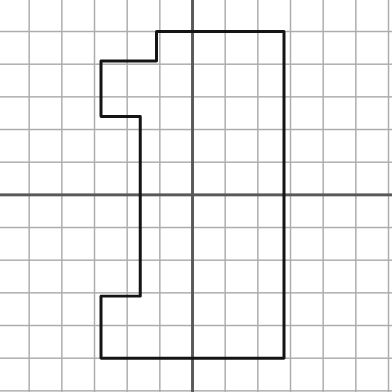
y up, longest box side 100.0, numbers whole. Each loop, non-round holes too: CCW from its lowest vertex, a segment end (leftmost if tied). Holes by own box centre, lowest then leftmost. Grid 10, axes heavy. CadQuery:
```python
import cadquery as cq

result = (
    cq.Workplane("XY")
    .moveTo(-28.0, -50.0)
    .lineTo(28.0, -50.0)
    .lineTo(28.0, 50.0)
    .lineTo(-11.0, 50.0)
    .lineTo(-11.0, 41.0)
    .lineTo(-28.0, 41.0)
    .lineTo(-28.0, 24.0)
    .lineTo(-16.0, 24.0)
    .lineTo(-16.0, -31.0)
    .lineTo(-28.0, -31.0)
    .close()
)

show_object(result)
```